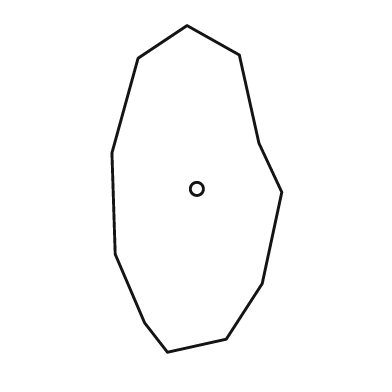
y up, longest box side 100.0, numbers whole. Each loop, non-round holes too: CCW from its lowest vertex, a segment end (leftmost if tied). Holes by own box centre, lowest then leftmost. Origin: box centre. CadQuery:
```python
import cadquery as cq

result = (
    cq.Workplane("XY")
    .moveTo(-9.0, -50.0)
    .lineTo(9.0, -46.0)
    .lineTo(20.0, -29.0)
    .lineTo(26.0, -1.0)
    .lineTo(19.0, 14.0)
    .lineTo(13.0, 41.0)
    .lineTo(-3.0, 50.0)
    .lineTo(-18.0, 40.0)
    .lineTo(-26.0, 11.0)
    .lineTo(-25.0, -20.0)
    .lineTo(-16.0, -41.0)
    .close()
    .moveTo(0.0, 0.0)
    .circle(2.0)
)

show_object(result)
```